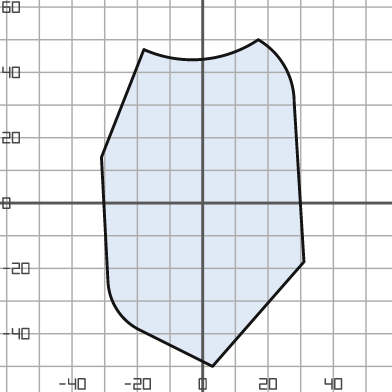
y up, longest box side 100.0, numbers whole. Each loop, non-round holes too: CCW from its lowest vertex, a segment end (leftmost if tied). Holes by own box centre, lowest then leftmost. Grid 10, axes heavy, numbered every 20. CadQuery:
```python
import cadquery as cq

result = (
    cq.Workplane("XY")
    .moveTo(3.0, -50.0)
    .lineTo(31.0, -18.0)
    .lineTo(28.0, 31.0)
    .threePointArc((25.0, 42.0), (17.0, 50.0))
    .threePointArc((0.0, 44.0), (-18.0, 47.0))
    .lineTo(-31.0, 14.0)
    .lineTo(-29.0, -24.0)
    .threePointArc((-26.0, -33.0), (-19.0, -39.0))
    .close()
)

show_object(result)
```